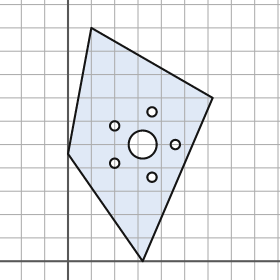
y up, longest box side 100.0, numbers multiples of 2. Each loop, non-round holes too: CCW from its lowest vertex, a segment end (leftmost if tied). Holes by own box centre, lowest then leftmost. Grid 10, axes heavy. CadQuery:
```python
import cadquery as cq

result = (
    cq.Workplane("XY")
    .moveTo(32.0, 0.0)
    .lineTo(62.0, 70.0)
    .lineTo(10.0, 100.0)
    .lineTo(0.0, 46.0)
    .close()
    .moveTo(36.0, 36.0)
    .circle(2.0)
    .moveTo(20.0, 42.0)
    .circle(2.0)
    .moveTo(32.0, 50.0)
    .circle(6.0)
    .moveTo(46.0, 50.0)
    .circle(2.0)
    .moveTo(20.0, 58.0)
    .circle(2.0)
    .moveTo(36.0, 64.0)
    .circle(2.0)
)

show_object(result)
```